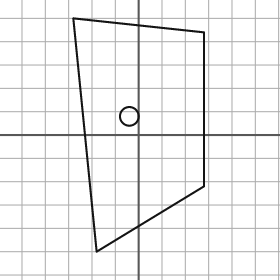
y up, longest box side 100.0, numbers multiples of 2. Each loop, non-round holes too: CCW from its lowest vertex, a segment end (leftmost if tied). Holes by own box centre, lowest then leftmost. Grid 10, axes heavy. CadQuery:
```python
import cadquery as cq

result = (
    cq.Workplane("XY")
    .moveTo(-18.0, -50.0)
    .lineTo(28.0, -22.0)
    .lineTo(28.0, 44.0)
    .lineTo(-28.0, 50.0)
    .close()
    .moveTo(-4.0, 8.0)
    .circle(4.0)
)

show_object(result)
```